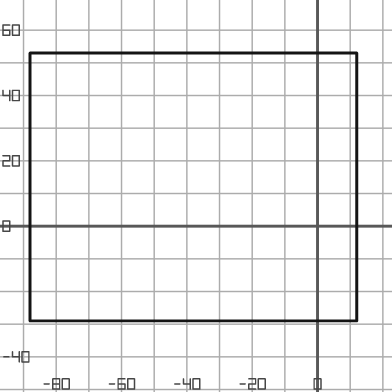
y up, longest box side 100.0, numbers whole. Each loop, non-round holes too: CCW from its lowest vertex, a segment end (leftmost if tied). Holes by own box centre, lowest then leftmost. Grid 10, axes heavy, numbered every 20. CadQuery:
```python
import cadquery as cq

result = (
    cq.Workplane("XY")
    .moveTo(-88.0, -29.0)
    .lineTo(12.0, -29.0)
    .lineTo(12.0, 53.0)
    .lineTo(-88.0, 53.0)
    .close()
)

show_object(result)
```